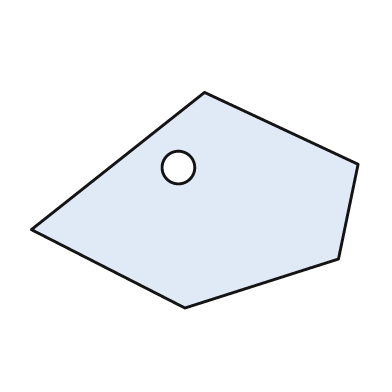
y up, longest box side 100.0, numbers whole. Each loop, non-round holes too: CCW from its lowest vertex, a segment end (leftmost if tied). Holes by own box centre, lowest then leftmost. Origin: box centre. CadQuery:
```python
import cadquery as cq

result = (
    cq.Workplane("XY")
    .moveTo(-3.0, -33.0)
    .lineTo(44.0, -18.0)
    .lineTo(50.0, 11.0)
    .lineTo(3.0, 33.0)
    .lineTo(-50.0, -9.0)
    .close()
    .moveTo(-5.0, 10.0)
    .circle(5.0)
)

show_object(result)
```